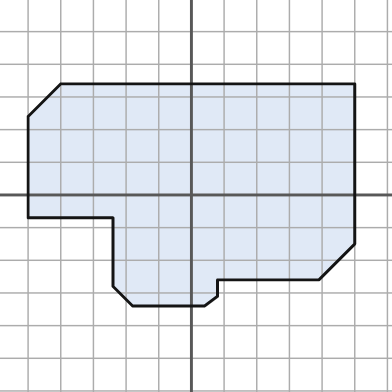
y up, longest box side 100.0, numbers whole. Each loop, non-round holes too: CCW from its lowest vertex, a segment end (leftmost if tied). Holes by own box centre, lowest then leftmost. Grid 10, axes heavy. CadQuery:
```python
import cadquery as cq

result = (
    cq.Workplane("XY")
    .moveTo(-18.0, -34.0)
    .lineTo(4.0, -34.0)
    .lineTo(8.0, -31.0)
    .lineTo(8.0, -26.0)
    .lineTo(39.0, -26.0)
    .lineTo(50.0, -15.0)
    .lineTo(50.0, 34.0)
    .lineTo(-40.0, 34.0)
    .lineTo(-50.0, 24.0)
    .lineTo(-50.0, -7.0)
    .lineTo(-24.0, -7.0)
    .lineTo(-24.0, -28.0)
    .close()
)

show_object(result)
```